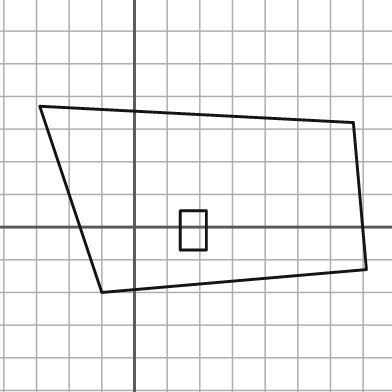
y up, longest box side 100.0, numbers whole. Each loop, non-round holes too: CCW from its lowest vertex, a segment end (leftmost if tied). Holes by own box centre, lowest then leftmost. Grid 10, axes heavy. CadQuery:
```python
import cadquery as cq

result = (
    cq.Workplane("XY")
    .moveTo(-10.0, -20.0)
    .lineTo(71.0, -13.0)
    .lineTo(67.0, 32.0)
    .lineTo(-29.0, 37.0)
    .close()
    .moveTo(14.0, -7.0)
    .lineTo(22.0, -7.0)
    .lineTo(22.0, 5.0)
    .lineTo(14.0, 5.0)
    .close()
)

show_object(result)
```